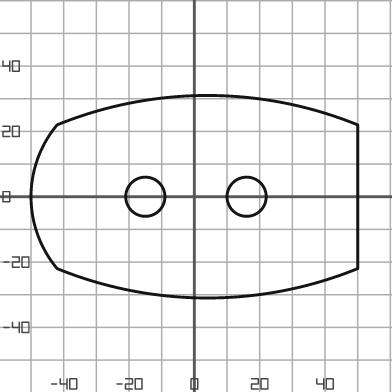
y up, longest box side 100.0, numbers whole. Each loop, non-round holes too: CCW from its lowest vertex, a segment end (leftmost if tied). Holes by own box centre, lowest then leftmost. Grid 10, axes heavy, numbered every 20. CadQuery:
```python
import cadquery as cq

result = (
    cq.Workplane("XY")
    .moveTo(-42.0, -22.0)
    .threePointArc((4.0, -31.0), (50.0, -22.0))
    .lineTo(50.0, 22.0)
    .threePointArc((4.0, 31.0), (-42.0, 22.0))
    .threePointArc((-50.0, 0.0), (-42.0, -22.0))
    .close()
    .moveTo(-15.0, 0.0)
    .circle(6.0)
    .moveTo(16.0, 0.0)
    .circle(6.0)
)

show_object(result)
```